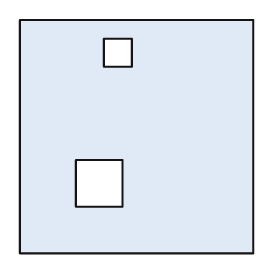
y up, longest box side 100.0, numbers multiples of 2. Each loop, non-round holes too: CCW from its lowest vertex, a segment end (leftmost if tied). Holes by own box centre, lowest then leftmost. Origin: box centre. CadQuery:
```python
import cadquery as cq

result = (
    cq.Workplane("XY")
    .moveTo(-50.0, -50.0)
    .lineTo(50.0, -50.0)
    .lineTo(50.0, 50.0)
    .lineTo(-50.0, 50.0)
    .close()
    .moveTo(-26.0, -30.0)
    .lineTo(-6.0, -30.0)
    .lineTo(-6.0, -10.0)
    .lineTo(-26.0, -10.0)
    .close()
    .moveTo(-14.0, 30.0)
    .lineTo(-2.0, 30.0)
    .lineTo(-2.0, 42.0)
    .lineTo(-14.0, 42.0)
    .close()
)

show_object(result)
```